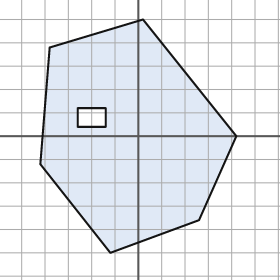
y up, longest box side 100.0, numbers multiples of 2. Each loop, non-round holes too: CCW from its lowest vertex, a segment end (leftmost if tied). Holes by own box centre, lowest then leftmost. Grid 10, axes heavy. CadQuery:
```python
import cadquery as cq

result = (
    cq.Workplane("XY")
    .moveTo(-12.0, -50.0)
    .lineTo(26.0, -36.0)
    .lineTo(42.0, 0.0)
    .lineTo(2.0, 50.0)
    .lineTo(-38.0, 38.0)
    .lineTo(-42.0, -12.0)
    .close()
    .moveTo(-26.0, 4.0)
    .lineTo(-14.0, 4.0)
    .lineTo(-14.0, 12.0)
    .lineTo(-26.0, 12.0)
    .close()
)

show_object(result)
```